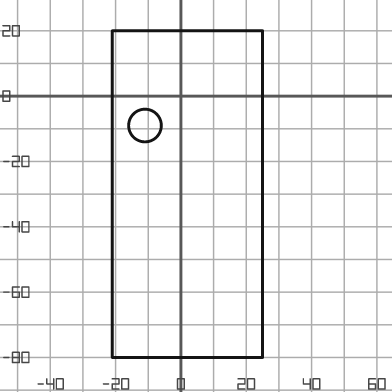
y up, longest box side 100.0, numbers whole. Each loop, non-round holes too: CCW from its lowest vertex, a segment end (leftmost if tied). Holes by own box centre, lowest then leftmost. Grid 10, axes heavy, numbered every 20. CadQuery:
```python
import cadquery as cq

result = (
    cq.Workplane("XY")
    .moveTo(-21.0, -80.0)
    .lineTo(25.0, -80.0)
    .lineTo(25.0, 20.0)
    .lineTo(-21.0, 20.0)
    .close()
    .moveTo(-11.0, -9.0)
    .circle(5.0)
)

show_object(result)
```